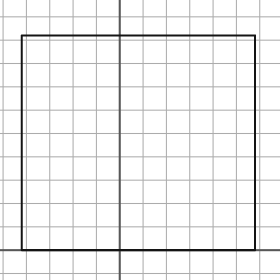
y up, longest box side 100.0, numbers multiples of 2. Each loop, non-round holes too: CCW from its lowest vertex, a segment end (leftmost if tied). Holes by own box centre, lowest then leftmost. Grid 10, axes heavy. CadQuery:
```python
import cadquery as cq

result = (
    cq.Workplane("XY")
    .moveTo(-42.0, 0.0)
    .lineTo(58.0, 0.0)
    .lineTo(58.0, 92.0)
    .lineTo(-42.0, 92.0)
    .close()
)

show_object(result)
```